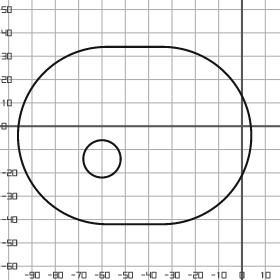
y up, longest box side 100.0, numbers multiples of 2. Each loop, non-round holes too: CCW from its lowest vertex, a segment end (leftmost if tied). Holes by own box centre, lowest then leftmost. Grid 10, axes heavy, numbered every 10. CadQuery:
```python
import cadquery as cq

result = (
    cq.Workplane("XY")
    .moveTo(-58.0, -42.0)
    .lineTo(-34.0, -42.0)
    .threePointArc((4.0, -4.0), (-34.0, 34.0))
    .lineTo(-58.0, 34.0)
    .threePointArc((-96.0, -4.0), (-58.0, -42.0))
    .close()
    .moveTo(-60.0, -14.0)
    .circle(8.0)
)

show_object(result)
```